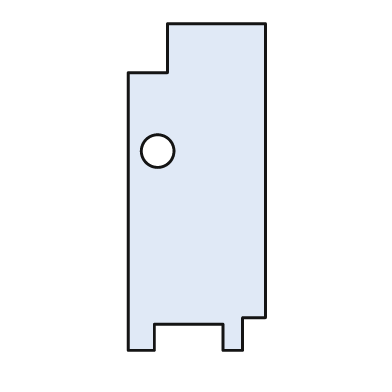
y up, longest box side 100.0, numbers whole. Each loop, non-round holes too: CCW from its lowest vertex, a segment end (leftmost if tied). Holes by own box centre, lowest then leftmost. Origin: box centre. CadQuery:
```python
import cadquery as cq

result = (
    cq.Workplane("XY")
    .moveTo(-21.0, -50.0)
    .lineTo(-13.0, -50.0)
    .lineTo(-13.0, -42.0)
    .lineTo(8.0, -42.0)
    .lineTo(8.0, -50.0)
    .lineTo(14.0, -50.0)
    .lineTo(14.0, -40.0)
    .lineTo(21.0, -40.0)
    .lineTo(21.0, 50.0)
    .lineTo(-9.0, 50.0)
    .lineTo(-9.0, 35.0)
    .lineTo(-21.0, 35.0)
    .close()
    .moveTo(-12.0, 11.0)
    .circle(5.0)
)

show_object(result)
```